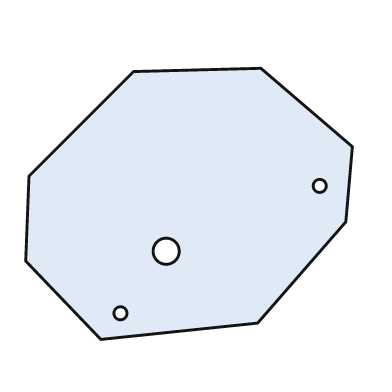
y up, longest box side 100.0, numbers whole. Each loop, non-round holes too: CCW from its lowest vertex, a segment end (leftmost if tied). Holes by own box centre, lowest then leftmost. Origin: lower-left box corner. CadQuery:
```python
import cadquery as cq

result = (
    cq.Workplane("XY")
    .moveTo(23.0, 0.0)
    .lineTo(71.0, 5.0)
    .lineTo(98.0, 36.0)
    .lineTo(100.0, 59.0)
    .lineTo(72.0, 83.0)
    .lineTo(33.0, 82.0)
    .lineTo(1.0, 50.0)
    .lineTo(0.0, 24.0)
    .close()
    .moveTo(29.0, 8.0)
    .circle(2.0)
    .moveTo(43.0, 27.0)
    .circle(4.0)
    .moveTo(90.0, 47.0)
    .circle(2.0)
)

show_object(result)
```